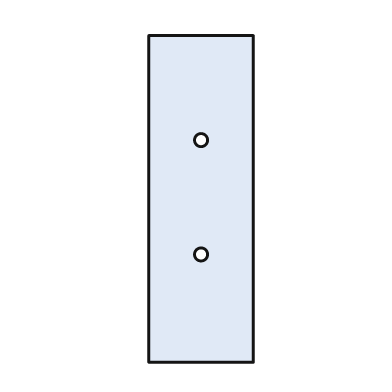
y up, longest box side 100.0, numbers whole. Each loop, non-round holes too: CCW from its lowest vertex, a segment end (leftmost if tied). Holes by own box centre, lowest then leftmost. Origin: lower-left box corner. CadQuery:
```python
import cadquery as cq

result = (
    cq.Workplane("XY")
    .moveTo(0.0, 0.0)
    .lineTo(32.0, 0.0)
    .lineTo(32.0, 100.0)
    .lineTo(0.0, 100.0)
    .close()
    .moveTo(16.0, 33.0)
    .circle(2.0)
    .moveTo(16.0, 68.0)
    .circle(2.0)
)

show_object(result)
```